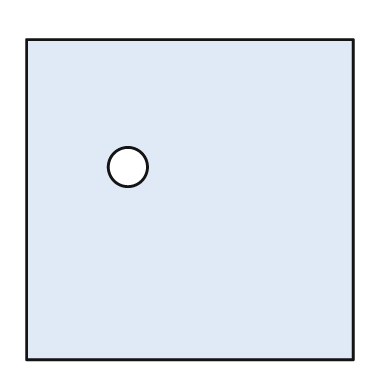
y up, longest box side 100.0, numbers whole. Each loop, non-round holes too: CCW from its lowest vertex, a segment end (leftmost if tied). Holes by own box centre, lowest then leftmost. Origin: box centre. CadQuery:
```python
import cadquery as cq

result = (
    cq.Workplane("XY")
    .moveTo(-50.0, -49.0)
    .lineTo(50.0, -49.0)
    .lineTo(50.0, 49.0)
    .lineTo(-50.0, 49.0)
    .close()
    .moveTo(-19.0, 10.0)
    .circle(6.0)
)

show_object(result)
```